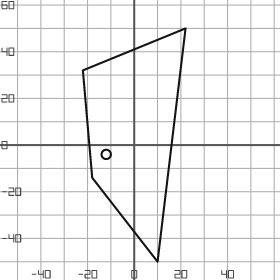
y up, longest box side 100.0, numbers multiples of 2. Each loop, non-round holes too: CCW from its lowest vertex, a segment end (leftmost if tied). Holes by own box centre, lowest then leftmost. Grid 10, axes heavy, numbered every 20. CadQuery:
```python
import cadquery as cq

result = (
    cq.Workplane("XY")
    .moveTo(10.0, -50.0)
    .lineTo(22.0, 50.0)
    .lineTo(-22.0, 32.0)
    .lineTo(-18.0, -14.0)
    .close()
    .moveTo(-12.0, -4.0)
    .circle(2.0)
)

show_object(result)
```